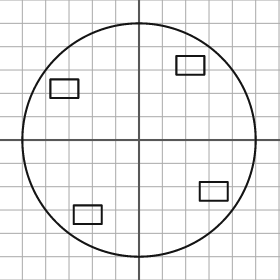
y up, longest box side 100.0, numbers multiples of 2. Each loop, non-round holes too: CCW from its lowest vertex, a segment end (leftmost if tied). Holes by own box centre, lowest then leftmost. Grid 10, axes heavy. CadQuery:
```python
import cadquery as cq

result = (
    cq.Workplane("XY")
    .moveTo(0.0, 0.0)
    .circle(50.0)
    .moveTo(-28.0, -36.0)
    .lineTo(-16.0, -36.0)
    .lineTo(-16.0, -28.0)
    .lineTo(-28.0, -28.0)
    .close()
    .moveTo(26.0, -26.0)
    .lineTo(38.0, -26.0)
    .lineTo(38.0, -18.0)
    .lineTo(26.0, -18.0)
    .close()
    .moveTo(-38.0, 18.0)
    .lineTo(-26.0, 18.0)
    .lineTo(-26.0, 26.0)
    .lineTo(-38.0, 26.0)
    .close()
    .moveTo(16.0, 28.0)
    .lineTo(28.0, 28.0)
    .lineTo(28.0, 36.0)
    .lineTo(16.0, 36.0)
    .close()
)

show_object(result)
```